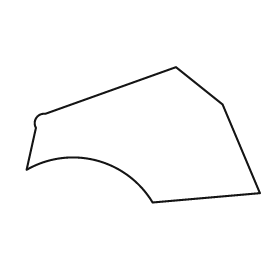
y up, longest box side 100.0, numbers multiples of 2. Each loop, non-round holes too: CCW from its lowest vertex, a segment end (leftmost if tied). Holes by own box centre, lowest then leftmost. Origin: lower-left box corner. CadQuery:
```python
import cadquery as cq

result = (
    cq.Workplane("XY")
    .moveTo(54.0, 0.0)
    .lineTo(100.0, 4.0)
    .lineTo(84.0, 42.0)
    .lineTo(64.0, 58.0)
    .lineTo(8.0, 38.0)
    .threePointArc((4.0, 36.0), (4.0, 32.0))
    .lineTo(0.0, 14.0)
    .threePointArc((30.0, 18.0), (54.0, 0.0))
    .close()
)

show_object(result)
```